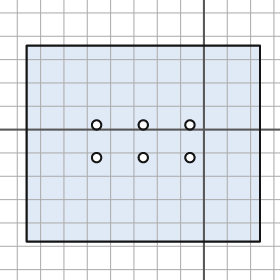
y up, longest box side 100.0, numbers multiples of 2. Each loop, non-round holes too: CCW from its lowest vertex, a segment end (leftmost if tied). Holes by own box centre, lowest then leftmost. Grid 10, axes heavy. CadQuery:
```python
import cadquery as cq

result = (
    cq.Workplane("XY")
    .moveTo(-76.0, -48.0)
    .lineTo(24.0, -48.0)
    .lineTo(24.0, 36.0)
    .lineTo(-76.0, 36.0)
    .close()
    .moveTo(-46.0, -12.0)
    .circle(2.0)
    .moveTo(-26.0, -12.0)
    .circle(2.0)
    .moveTo(-6.0, -12.0)
    .circle(2.0)
    .moveTo(-46.0, 2.0)
    .circle(2.0)
    .moveTo(-26.0, 2.0)
    .circle(2.0)
    .moveTo(-6.0, 2.0)
    .circle(2.0)
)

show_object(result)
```